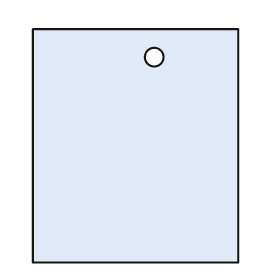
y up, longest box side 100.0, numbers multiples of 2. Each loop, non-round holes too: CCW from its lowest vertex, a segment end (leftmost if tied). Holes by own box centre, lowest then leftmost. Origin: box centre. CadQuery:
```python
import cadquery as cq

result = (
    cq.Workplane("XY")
    .moveTo(-44.0, -50.0)
    .lineTo(44.0, -50.0)
    .lineTo(44.0, 50.0)
    .lineTo(-44.0, 50.0)
    .close()
    .moveTo(8.0, 38.0)
    .circle(4.0)
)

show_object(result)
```